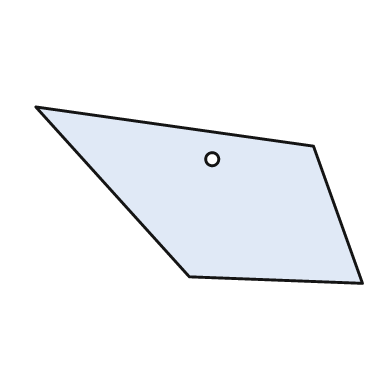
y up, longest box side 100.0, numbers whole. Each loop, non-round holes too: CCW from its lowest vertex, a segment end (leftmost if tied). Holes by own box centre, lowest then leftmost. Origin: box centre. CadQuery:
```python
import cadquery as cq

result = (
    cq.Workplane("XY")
    .moveTo(50.0, -27.0)
    .lineTo(35.0, 15.0)
    .lineTo(-50.0, 27.0)
    .lineTo(-3.0, -25.0)
    .close()
    .moveTo(4.0, 11.0)
    .circle(2.0)
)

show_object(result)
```